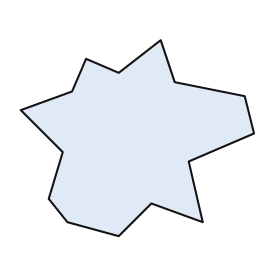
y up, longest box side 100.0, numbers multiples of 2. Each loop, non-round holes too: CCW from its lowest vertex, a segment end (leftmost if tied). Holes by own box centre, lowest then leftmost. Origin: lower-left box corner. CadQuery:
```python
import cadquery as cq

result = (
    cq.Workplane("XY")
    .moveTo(42.0, 0.0)
    .lineTo(56.0, 14.0)
    .lineTo(78.0, 6.0)
    .lineTo(72.0, 32.0)
    .lineTo(100.0, 44.0)
    .lineTo(96.0, 60.0)
    .lineTo(66.0, 66.0)
    .lineTo(60.0, 84.0)
    .lineTo(42.0, 70.0)
    .lineTo(28.0, 76.0)
    .lineTo(22.0, 62.0)
    .lineTo(0.0, 54.0)
    .lineTo(18.0, 36.0)
    .lineTo(12.0, 16.0)
    .lineTo(20.0, 6.0)
    .close()
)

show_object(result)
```